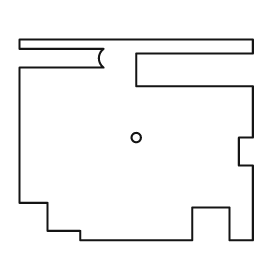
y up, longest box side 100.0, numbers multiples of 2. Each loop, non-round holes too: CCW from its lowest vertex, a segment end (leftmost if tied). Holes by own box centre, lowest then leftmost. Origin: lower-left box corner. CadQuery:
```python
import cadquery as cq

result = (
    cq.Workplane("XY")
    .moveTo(26.0, 0.0)
    .lineTo(74.0, 0.0)
    .lineTo(74.0, 14.0)
    .lineTo(90.0, 14.0)
    .lineTo(90.0, 0.0)
    .lineTo(100.0, 0.0)
    .lineTo(100.0, 32.0)
    .lineTo(94.0, 32.0)
    .lineTo(94.0, 44.0)
    .lineTo(100.0, 44.0)
    .lineTo(100.0, 66.0)
    .lineTo(50.0, 66.0)
    .lineTo(50.0, 80.0)
    .lineTo(100.0, 80.0)
    .lineTo(100.0, 86.0)
    .lineTo(0.0, 86.0)
    .lineTo(0.0, 82.0)
    .lineTo(36.0, 82.0)
    .threePointArc((34.0, 78.0), (36.0, 74.0))
    .lineTo(0.0, 74.0)
    .lineTo(0.0, 16.0)
    .lineTo(12.0, 16.0)
    .lineTo(12.0, 4.0)
    .lineTo(26.0, 4.0)
    .close()
    .moveTo(50.0, 44.0)
    .circle(2.0)
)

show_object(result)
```